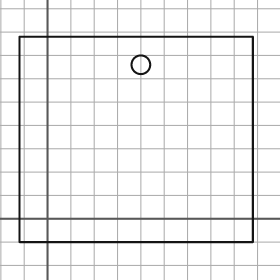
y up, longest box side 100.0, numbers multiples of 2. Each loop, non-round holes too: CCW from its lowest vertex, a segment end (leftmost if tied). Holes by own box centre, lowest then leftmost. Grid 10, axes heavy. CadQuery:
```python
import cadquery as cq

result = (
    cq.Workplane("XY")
    .moveTo(-12.0, -10.0)
    .lineTo(88.0, -10.0)
    .lineTo(88.0, 78.0)
    .lineTo(-12.0, 78.0)
    .close()
    .moveTo(40.0, 66.0)
    .circle(4.0)
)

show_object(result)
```